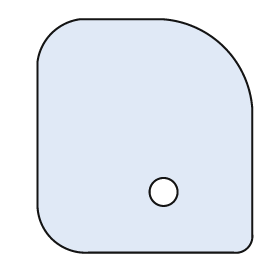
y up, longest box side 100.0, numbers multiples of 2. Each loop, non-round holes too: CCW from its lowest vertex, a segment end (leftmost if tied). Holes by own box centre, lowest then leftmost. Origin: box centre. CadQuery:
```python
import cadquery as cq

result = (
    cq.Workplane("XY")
    .moveTo(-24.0, -50.0)
    .lineTo(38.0, -50.0)
    .threePointArc((44.0, -48.0), (46.0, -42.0))
    .lineTo(46.0, 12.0)
    .threePointArc((34.0, 38.0), (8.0, 50.0))
    .lineTo(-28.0, 50.0)
    .threePointArc((-40.0, 44.0), (-46.0, 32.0))
    .lineTo(-46.0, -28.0)
    .threePointArc((-40.0, -44.0), (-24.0, -50.0))
    .close()
    .moveTo(8.0, -24.0)
    .circle(6.0)
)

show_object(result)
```